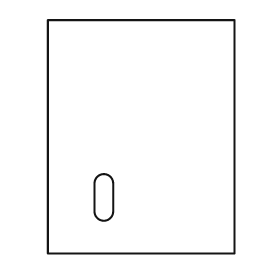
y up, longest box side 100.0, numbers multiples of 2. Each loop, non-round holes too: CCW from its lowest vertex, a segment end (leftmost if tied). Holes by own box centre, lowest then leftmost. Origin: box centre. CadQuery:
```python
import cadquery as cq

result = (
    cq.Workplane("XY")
    .moveTo(-40.0, -50.0)
    .lineTo(40.0, -50.0)
    .lineTo(40.0, 50.0)
    .lineTo(-40.0, 50.0)
    .close()
    .moveTo(-20.0, -32.0)
    .threePointArc((-16.0, -36.0), (-12.0, -32.0))
    .lineTo(-12.0, -20.0)
    .threePointArc((-16.0, -16.0), (-20.0, -20.0))
    .close()
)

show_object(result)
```